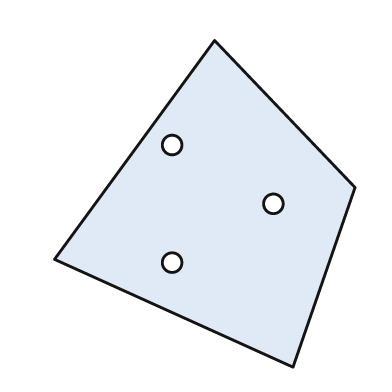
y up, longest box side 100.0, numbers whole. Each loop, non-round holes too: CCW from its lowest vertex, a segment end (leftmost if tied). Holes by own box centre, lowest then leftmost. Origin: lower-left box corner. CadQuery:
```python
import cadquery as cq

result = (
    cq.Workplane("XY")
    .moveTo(73.0, 0.0)
    .lineTo(92.0, 55.0)
    .lineTo(49.0, 100.0)
    .lineTo(0.0, 33.0)
    .close()
    .moveTo(36.0, 32.0)
    .circle(3.0)
    .moveTo(67.0, 50.0)
    .circle(3.0)
    .moveTo(36.0, 68.0)
    .circle(3.0)
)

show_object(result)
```